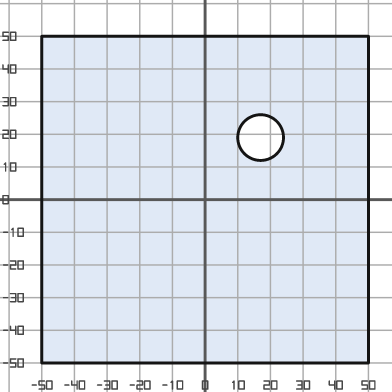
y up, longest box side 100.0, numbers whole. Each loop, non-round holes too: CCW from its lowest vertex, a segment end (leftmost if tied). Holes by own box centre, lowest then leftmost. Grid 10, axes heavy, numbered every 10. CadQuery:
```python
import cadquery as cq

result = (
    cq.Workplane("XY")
    .moveTo(-50.0, -50.0)
    .lineTo(50.0, -50.0)
    .lineTo(50.0, 50.0)
    .lineTo(-50.0, 50.0)
    .close()
    .moveTo(17.0, 19.0)
    .circle(7.0)
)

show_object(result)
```